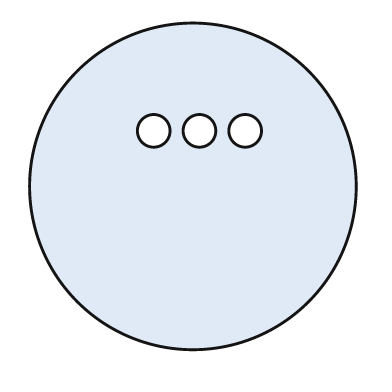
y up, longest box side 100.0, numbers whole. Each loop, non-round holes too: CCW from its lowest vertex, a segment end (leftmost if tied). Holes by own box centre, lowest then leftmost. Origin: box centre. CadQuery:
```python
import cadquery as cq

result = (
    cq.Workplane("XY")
    .moveTo(0.0, 0.0)
    .circle(50.0)
    .moveTo(-12.0, 17.0)
    .circle(5.0)
    .moveTo(2.0, 17.0)
    .circle(5.0)
    .moveTo(16.0, 17.0)
    .circle(5.0)
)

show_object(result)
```